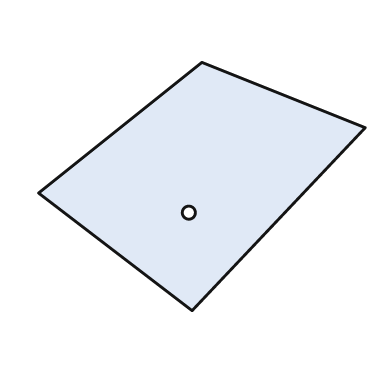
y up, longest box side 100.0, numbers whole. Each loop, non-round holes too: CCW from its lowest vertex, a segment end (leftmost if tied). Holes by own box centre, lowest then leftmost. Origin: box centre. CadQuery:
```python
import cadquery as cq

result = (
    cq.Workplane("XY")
    .moveTo(-3.0, -38.0)
    .lineTo(50.0, 18.0)
    .lineTo(0.0, 38.0)
    .lineTo(-50.0, -2.0)
    .close()
    .moveTo(-4.0, -8.0)
    .circle(2.0)
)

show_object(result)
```